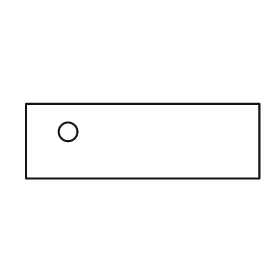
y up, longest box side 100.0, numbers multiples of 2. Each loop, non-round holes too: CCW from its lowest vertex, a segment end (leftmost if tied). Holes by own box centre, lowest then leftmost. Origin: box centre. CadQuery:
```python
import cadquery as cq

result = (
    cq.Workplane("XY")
    .moveTo(-50.0, -16.0)
    .lineTo(50.0, -16.0)
    .lineTo(50.0, 16.0)
    .lineTo(-50.0, 16.0)
    .close()
    .moveTo(-32.0, 4.0)
    .circle(4.0)
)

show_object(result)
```